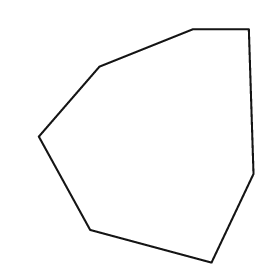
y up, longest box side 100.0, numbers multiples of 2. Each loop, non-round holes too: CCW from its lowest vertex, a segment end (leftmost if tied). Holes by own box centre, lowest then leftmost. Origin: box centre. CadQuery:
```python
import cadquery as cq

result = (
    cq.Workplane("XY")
    .moveTo(28.0, -50.0)
    .lineTo(46.0, -12.0)
    .lineTo(44.0, 50.0)
    .lineTo(20.0, 50.0)
    .lineTo(-20.0, 34.0)
    .lineTo(-46.0, 4.0)
    .lineTo(-24.0, -36.0)
    .close()
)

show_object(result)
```